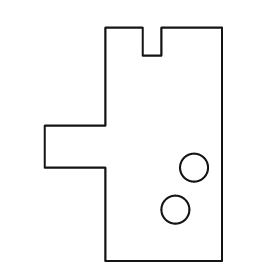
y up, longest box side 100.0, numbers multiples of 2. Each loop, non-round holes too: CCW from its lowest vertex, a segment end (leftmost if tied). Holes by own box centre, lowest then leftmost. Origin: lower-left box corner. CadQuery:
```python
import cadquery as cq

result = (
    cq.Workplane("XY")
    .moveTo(26.0, 0.0)
    .lineTo(76.0, 0.0)
    .lineTo(76.0, 100.0)
    .lineTo(50.0, 100.0)
    .lineTo(50.0, 88.0)
    .lineTo(42.0, 88.0)
    .lineTo(42.0, 100.0)
    .lineTo(26.0, 100.0)
    .lineTo(26.0, 58.0)
    .lineTo(0.0, 58.0)
    .lineTo(0.0, 40.0)
    .lineTo(26.0, 40.0)
    .close()
    .moveTo(56.0, 22.0)
    .circle(6.0)
    .moveTo(64.0, 40.0)
    .circle(6.0)
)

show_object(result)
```